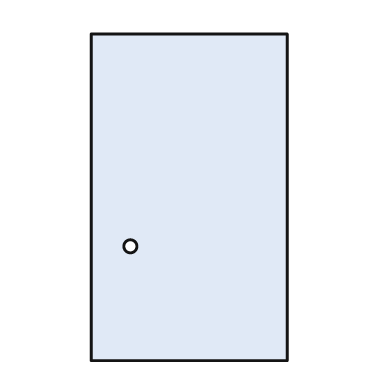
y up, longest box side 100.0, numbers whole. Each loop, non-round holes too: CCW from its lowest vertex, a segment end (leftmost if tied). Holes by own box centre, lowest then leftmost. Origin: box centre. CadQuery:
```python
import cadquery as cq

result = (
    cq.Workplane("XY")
    .moveTo(-30.0, -50.0)
    .lineTo(30.0, -50.0)
    .lineTo(30.0, 50.0)
    .lineTo(-30.0, 50.0)
    .close()
    .moveTo(-18.0, -15.0)
    .circle(2.0)
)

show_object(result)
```